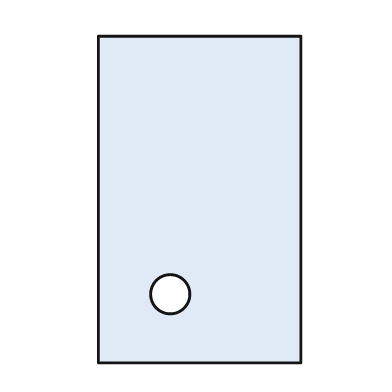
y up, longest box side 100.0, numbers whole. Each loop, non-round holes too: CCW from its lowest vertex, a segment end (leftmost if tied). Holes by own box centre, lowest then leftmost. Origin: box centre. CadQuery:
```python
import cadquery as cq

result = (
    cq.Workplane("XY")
    .moveTo(-31.0, -50.0)
    .lineTo(31.0, -50.0)
    .lineTo(31.0, 50.0)
    .lineTo(-31.0, 50.0)
    .close()
    .moveTo(-9.0, -29.0)
    .circle(6.0)
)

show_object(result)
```